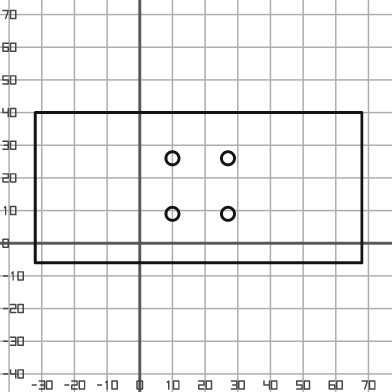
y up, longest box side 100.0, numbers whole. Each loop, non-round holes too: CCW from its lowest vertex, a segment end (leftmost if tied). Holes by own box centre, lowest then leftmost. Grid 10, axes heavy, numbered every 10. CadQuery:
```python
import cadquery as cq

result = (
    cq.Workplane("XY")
    .moveTo(-32.0, -6.0)
    .lineTo(68.0, -6.0)
    .lineTo(68.0, 40.0)
    .lineTo(-32.0, 40.0)
    .close()
    .moveTo(10.0, 9.0)
    .circle(2.0)
    .moveTo(27.0, 9.0)
    .circle(2.0)
    .moveTo(10.0, 26.0)
    .circle(2.0)
    .moveTo(27.0, 26.0)
    .circle(2.0)
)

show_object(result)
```